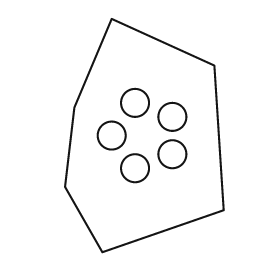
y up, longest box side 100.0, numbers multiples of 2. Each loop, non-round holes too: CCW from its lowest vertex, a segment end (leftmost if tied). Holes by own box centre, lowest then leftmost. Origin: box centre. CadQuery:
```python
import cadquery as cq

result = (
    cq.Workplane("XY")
    .moveTo(-18.0, -50.0)
    .lineTo(34.0, -32.0)
    .lineTo(30.0, 30.0)
    .lineTo(-14.0, 50.0)
    .lineTo(-30.0, 12.0)
    .lineTo(-34.0, -22.0)
    .close()
    .moveTo(-4.0, -14.0)
    .circle(6.0)
    .moveTo(12.0, -8.0)
    .circle(6.0)
    .moveTo(-14.0, 0.0)
    .circle(6.0)
    .moveTo(12.0, 8.0)
    .circle(6.0)
    .moveTo(-4.0, 14.0)
    .circle(6.0)
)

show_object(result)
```